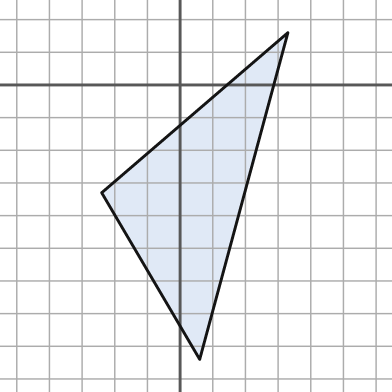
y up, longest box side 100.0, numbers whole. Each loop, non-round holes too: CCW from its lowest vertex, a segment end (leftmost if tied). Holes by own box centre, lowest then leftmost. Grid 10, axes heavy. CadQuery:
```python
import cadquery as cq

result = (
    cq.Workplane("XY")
    .moveTo(6.0, -84.0)
    .lineTo(33.0, 16.0)
    .lineTo(-24.0, -33.0)
    .close()
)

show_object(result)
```